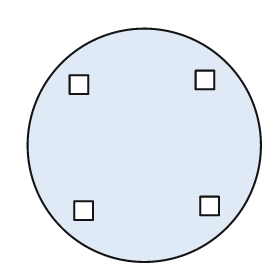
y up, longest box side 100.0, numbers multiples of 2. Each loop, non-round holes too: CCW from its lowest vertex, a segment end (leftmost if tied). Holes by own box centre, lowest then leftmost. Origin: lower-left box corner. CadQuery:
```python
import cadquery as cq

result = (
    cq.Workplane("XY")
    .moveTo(50.0, 50.0)
    .circle(50.0)
    .moveTo(20.0, 18.0)
    .lineTo(28.0, 18.0)
    .lineTo(28.0, 26.0)
    .lineTo(20.0, 26.0)
    .close()
    .moveTo(74.0, 20.0)
    .lineTo(82.0, 20.0)
    .lineTo(82.0, 28.0)
    .lineTo(74.0, 28.0)
    .close()
    .moveTo(18.0, 72.0)
    .lineTo(26.0, 72.0)
    .lineTo(26.0, 80.0)
    .lineTo(18.0, 80.0)
    .close()
    .moveTo(72.0, 74.0)
    .lineTo(80.0, 74.0)
    .lineTo(80.0, 82.0)
    .lineTo(72.0, 82.0)
    .close()
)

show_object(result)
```